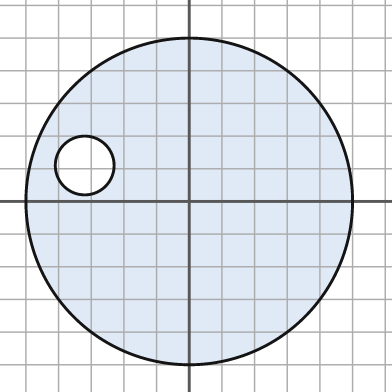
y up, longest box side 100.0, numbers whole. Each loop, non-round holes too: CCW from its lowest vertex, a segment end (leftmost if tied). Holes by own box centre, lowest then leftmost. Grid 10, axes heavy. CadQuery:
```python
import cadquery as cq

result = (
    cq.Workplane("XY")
    .moveTo(0.0, 0.0)
    .circle(50.0)
    .moveTo(-32.0, 11.0)
    .circle(9.0)
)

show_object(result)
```